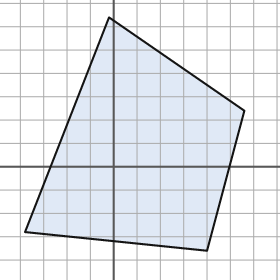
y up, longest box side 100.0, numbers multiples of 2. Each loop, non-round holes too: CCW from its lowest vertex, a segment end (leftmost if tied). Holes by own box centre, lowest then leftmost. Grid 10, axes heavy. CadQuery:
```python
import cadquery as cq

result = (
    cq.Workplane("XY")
    .moveTo(40.0, -36.0)
    .lineTo(56.0, 24.0)
    .lineTo(-2.0, 64.0)
    .lineTo(-38.0, -28.0)
    .close()
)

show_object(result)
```